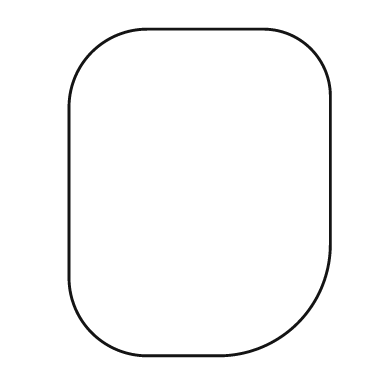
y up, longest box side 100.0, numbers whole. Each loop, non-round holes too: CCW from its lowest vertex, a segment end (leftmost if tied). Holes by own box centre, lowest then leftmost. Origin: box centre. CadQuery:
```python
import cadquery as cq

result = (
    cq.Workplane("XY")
    .moveTo(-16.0, -50.0)
    .lineTo(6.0, -50.0)
    .threePointArc((30.0, -40.0), (40.0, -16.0))
    .lineTo(40.0, 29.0)
    .threePointArc((34.0, 44.0), (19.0, 50.0))
    .lineTo(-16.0, 50.0)
    .threePointArc((-33.0, 43.0), (-40.0, 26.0))
    .lineTo(-40.0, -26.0)
    .threePointArc((-33.0, -43.0), (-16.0, -50.0))
    .close()
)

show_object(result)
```